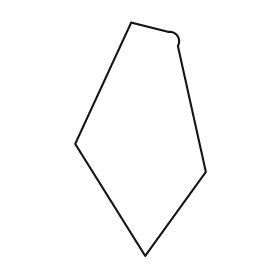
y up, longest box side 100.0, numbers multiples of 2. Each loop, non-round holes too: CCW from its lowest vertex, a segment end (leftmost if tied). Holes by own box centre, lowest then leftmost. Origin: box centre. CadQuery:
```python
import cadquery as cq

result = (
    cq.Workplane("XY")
    .moveTo(2.0, -50.0)
    .lineTo(28.0, -14.0)
    .lineTo(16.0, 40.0)
    .threePointArc((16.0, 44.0), (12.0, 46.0))
    .lineTo(-4.0, 50.0)
    .lineTo(-28.0, -2.0)
    .close()
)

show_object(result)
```